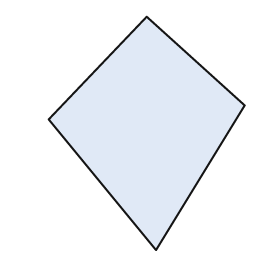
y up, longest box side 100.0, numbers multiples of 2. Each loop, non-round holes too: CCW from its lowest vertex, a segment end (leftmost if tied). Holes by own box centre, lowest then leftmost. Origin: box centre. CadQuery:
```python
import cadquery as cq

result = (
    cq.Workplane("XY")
    .moveTo(4.0, -50.0)
    .lineTo(42.0, 12.0)
    .lineTo(0.0, 50.0)
    .lineTo(-42.0, 6.0)
    .close()
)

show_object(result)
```